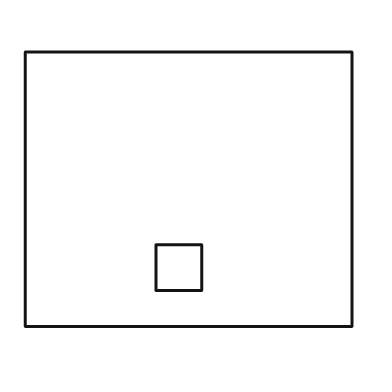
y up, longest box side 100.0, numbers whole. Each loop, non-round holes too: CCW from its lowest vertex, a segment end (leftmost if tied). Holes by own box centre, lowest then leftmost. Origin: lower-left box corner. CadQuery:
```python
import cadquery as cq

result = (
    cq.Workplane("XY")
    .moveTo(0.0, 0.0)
    .lineTo(100.0, 0.0)
    .lineTo(100.0, 84.0)
    .lineTo(0.0, 84.0)
    .close()
    .moveTo(40.0, 11.0)
    .lineTo(54.0, 11.0)
    .lineTo(54.0, 25.0)
    .lineTo(40.0, 25.0)
    .close()
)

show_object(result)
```